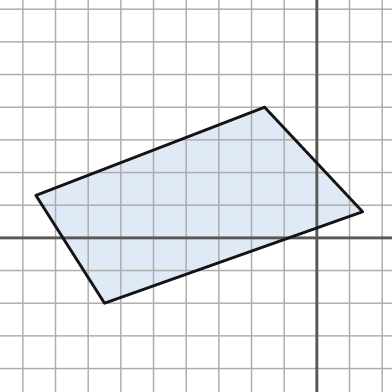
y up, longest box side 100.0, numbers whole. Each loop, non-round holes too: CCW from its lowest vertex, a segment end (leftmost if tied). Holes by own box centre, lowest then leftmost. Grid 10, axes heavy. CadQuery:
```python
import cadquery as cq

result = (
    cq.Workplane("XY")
    .moveTo(-65.0, -20.0)
    .lineTo(14.0, 8.0)
    .lineTo(-16.0, 40.0)
    .lineTo(-86.0, 13.0)
    .close()
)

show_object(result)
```